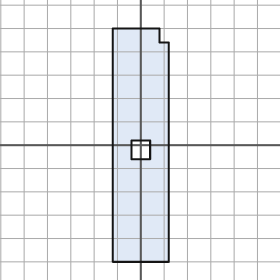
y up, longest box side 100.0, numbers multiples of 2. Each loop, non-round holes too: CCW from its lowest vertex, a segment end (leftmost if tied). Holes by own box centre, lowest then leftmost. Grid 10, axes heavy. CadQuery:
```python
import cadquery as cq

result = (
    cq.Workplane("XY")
    .moveTo(-12.0, -50.0)
    .lineTo(12.0, -50.0)
    .lineTo(12.0, 44.0)
    .lineTo(8.0, 44.0)
    .lineTo(8.0, 50.0)
    .lineTo(-12.0, 50.0)
    .close()
    .moveTo(-4.0, -6.0)
    .lineTo(4.0, -6.0)
    .lineTo(4.0, 2.0)
    .lineTo(-4.0, 2.0)
    .close()
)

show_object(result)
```